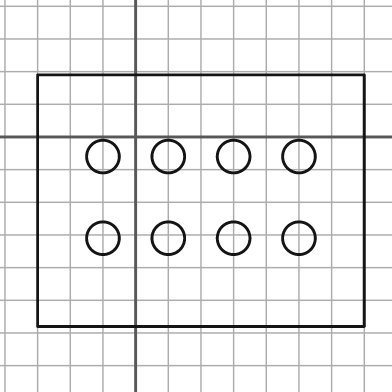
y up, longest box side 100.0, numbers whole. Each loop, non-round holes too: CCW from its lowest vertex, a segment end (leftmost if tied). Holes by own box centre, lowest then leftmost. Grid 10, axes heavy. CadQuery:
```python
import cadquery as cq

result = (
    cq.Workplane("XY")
    .moveTo(-30.0, -58.0)
    .lineTo(70.0, -58.0)
    .lineTo(70.0, 19.0)
    .lineTo(-30.0, 19.0)
    .close()
    .moveTo(-10.0, -31.0)
    .circle(5.0)
    .moveTo(10.0, -31.0)
    .circle(5.0)
    .moveTo(30.0, -31.0)
    .circle(5.0)
    .moveTo(50.0, -31.0)
    .circle(5.0)
    .moveTo(-10.0, -6.0)
    .circle(5.0)
    .moveTo(10.0, -6.0)
    .circle(5.0)
    .moveTo(30.0, -6.0)
    .circle(5.0)
    .moveTo(50.0, -6.0)
    .circle(5.0)
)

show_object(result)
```